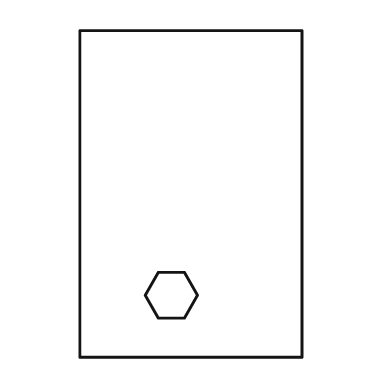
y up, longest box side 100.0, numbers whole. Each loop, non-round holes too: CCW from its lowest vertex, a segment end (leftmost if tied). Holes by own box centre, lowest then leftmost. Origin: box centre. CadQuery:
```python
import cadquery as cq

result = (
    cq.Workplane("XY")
    .moveTo(-34.0, -50.0)
    .lineTo(34.0, -50.0)
    .lineTo(34.0, 50.0)
    .lineTo(-34.0, 50.0)
    .close()
    .moveTo(-10.0, -38.0)
    .lineTo(-2.0, -38.0)
    .lineTo(2.0, -31.0)
    .lineTo(-2.0, -24.0)
    .lineTo(-10.0, -24.0)
    .lineTo(-14.0, -31.0)
    .close()
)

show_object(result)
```